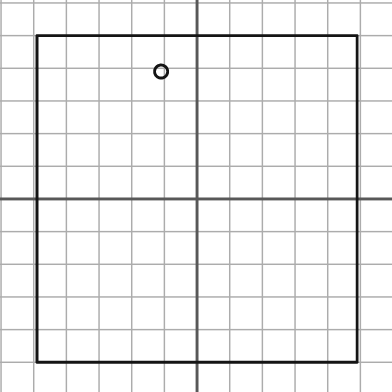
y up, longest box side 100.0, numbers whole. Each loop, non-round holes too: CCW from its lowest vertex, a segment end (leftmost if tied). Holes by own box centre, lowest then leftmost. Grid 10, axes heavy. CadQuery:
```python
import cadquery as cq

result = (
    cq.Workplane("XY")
    .moveTo(-49.0, -50.0)
    .lineTo(49.0, -50.0)
    .lineTo(49.0, 50.0)
    .lineTo(-49.0, 50.0)
    .close()
    .moveTo(-11.0, 39.0)
    .circle(2.0)
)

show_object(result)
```